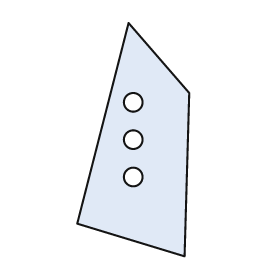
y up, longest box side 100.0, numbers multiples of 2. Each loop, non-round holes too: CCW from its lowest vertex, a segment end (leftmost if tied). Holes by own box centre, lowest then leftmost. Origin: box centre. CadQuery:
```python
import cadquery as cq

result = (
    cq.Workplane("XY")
    .moveTo(22.0, -50.0)
    .lineTo(24.0, 20.0)
    .lineTo(-2.0, 50.0)
    .lineTo(-24.0, -36.0)
    .close()
    .moveTo(0.0, -16.0)
    .circle(4.0)
    .moveTo(0.0, 0.0)
    .circle(4.0)
    .moveTo(0.0, 16.0)
    .circle(4.0)
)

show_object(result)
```